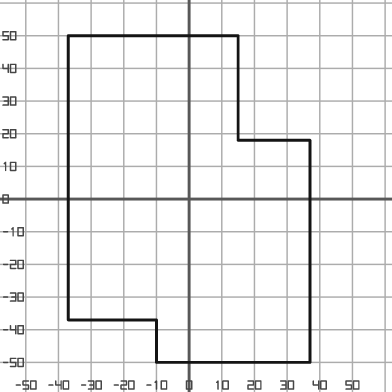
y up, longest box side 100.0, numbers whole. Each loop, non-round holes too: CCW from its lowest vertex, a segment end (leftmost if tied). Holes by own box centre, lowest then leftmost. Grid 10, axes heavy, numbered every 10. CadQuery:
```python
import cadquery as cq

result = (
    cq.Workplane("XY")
    .moveTo(-10.0, -50.0)
    .lineTo(37.0, -50.0)
    .lineTo(37.0, 18.0)
    .lineTo(15.0, 18.0)
    .lineTo(15.0, 50.0)
    .lineTo(-37.0, 50.0)
    .lineTo(-37.0, -37.0)
    .lineTo(-10.0, -37.0)
    .close()
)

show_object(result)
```